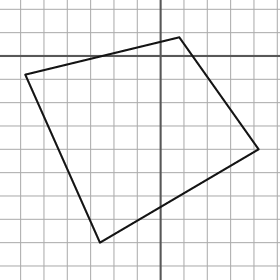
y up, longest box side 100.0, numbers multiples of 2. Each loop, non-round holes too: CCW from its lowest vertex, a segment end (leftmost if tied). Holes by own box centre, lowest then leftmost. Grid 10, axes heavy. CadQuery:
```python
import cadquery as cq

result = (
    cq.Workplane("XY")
    .moveTo(-26.0, -80.0)
    .lineTo(42.0, -40.0)
    .lineTo(8.0, 8.0)
    .lineTo(-58.0, -8.0)
    .close()
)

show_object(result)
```